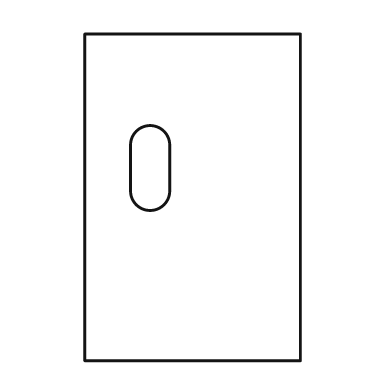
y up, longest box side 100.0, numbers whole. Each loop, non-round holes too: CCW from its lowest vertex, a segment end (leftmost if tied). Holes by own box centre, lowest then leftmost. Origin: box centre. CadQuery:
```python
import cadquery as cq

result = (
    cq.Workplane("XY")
    .moveTo(-33.0, -50.0)
    .lineTo(33.0, -50.0)
    .lineTo(33.0, 50.0)
    .lineTo(-33.0, 50.0)
    .close()
    .moveTo(-19.0, 2.0)
    .threePointArc((-13.0, -4.0), (-7.0, 2.0))
    .lineTo(-7.0, 16.0)
    .threePointArc((-13.0, 22.0), (-19.0, 16.0))
    .close()
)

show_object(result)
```